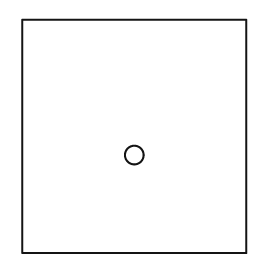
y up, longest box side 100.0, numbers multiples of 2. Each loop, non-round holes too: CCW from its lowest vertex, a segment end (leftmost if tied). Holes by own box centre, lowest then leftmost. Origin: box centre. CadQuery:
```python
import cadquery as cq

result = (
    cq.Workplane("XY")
    .moveTo(-48.0, -50.0)
    .lineTo(48.0, -50.0)
    .lineTo(48.0, 50.0)
    .lineTo(-48.0, 50.0)
    .close()
    .moveTo(0.0, -8.0)
    .circle(4.0)
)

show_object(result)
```